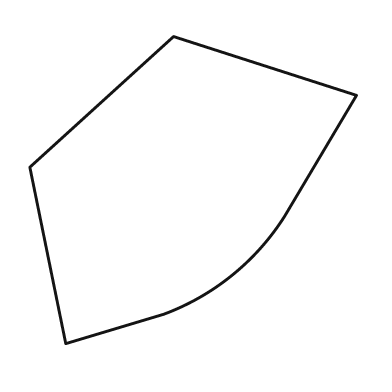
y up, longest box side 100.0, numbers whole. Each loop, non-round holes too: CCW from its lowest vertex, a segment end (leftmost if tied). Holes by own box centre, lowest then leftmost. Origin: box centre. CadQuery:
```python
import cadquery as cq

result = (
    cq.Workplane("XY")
    .moveTo(-39.0, -47.0)
    .lineTo(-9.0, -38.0)
    .threePointArc((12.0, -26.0), (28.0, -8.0))
    .lineTo(50.0, 29.0)
    .lineTo(-6.0, 47.0)
    .lineTo(-50.0, 7.0)
    .close()
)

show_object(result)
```